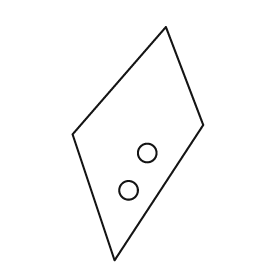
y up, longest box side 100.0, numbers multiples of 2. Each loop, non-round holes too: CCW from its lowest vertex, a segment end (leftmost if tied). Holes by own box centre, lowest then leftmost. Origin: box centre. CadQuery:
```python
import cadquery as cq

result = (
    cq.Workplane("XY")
    .moveTo(-10.0, -50.0)
    .lineTo(28.0, 8.0)
    .lineTo(12.0, 50.0)
    .lineTo(-28.0, 4.0)
    .close()
    .moveTo(-4.0, -20.0)
    .circle(4.0)
    .moveTo(4.0, -4.0)
    .circle(4.0)
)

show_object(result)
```